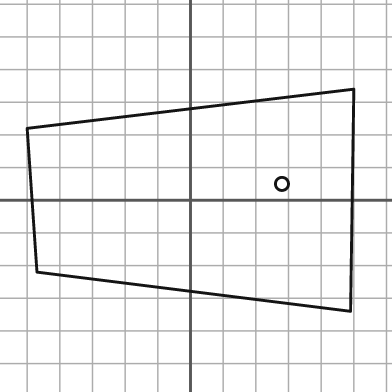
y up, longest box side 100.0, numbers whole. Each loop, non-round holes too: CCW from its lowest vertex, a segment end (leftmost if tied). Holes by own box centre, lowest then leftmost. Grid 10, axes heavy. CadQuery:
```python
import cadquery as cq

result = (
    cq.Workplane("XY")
    .moveTo(49.0, -34.0)
    .lineTo(50.0, 34.0)
    .lineTo(-50.0, 22.0)
    .lineTo(-47.0, -22.0)
    .close()
    .moveTo(28.0, 5.0)
    .circle(2.0)
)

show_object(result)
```